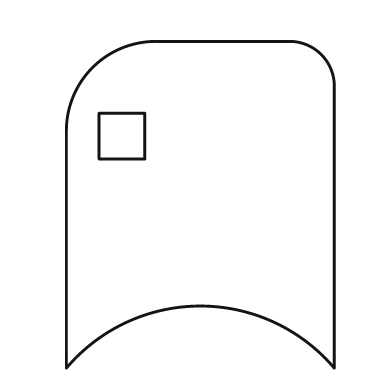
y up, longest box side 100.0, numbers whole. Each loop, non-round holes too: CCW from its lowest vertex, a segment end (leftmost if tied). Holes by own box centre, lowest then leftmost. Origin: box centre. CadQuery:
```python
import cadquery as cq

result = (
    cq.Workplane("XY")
    .moveTo(-41.0, -50.0)
    .threePointArc((0.0, -31.0), (41.0, -50.0))
    .lineTo(41.0, 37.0)
    .threePointArc((37.0, 46.0), (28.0, 50.0))
    .lineTo(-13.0, 50.0)
    .threePointArc((-33.0, 42.0), (-41.0, 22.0))
    .close()
    .moveTo(-31.0, 14.0)
    .lineTo(-17.0, 14.0)
    .lineTo(-17.0, 28.0)
    .lineTo(-31.0, 28.0)
    .close()
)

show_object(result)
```